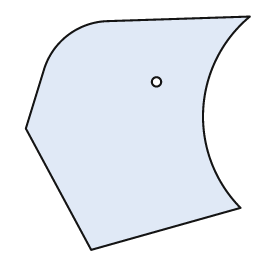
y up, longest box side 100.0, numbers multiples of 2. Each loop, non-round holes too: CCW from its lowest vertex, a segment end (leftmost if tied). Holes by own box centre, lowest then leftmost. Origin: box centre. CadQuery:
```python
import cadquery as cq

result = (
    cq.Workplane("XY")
    .moveTo(-20.0, -50.0)
    .lineTo(44.0, -32.0)
    .threePointArc((28.0, 10.0), (48.0, 50.0))
    .lineTo(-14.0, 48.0)
    .threePointArc((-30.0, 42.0), (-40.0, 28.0))
    .lineTo(-48.0, 2.0)
    .close()
    .moveTo(8.0, 22.0)
    .circle(2.0)
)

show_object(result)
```